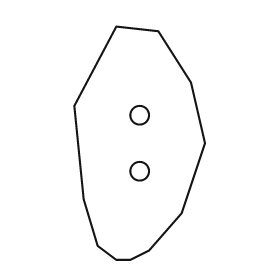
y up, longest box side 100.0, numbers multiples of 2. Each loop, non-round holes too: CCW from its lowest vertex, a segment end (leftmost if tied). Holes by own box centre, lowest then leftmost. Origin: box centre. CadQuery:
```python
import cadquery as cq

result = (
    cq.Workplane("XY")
    .moveTo(-10.0, -50.0)
    .lineTo(-4.0, -50.0)
    .lineTo(4.0, -46.0)
    .lineTo(18.0, -30.0)
    .lineTo(28.0, 0.0)
    .lineTo(22.0, 26.0)
    .lineTo(8.0, 48.0)
    .lineTo(-10.0, 50.0)
    .lineTo(-28.0, 16.0)
    .lineTo(-24.0, -24.0)
    .lineTo(-18.0, -44.0)
    .close()
    .moveTo(0.0, -12.0)
    .circle(4.0)
    .moveTo(0.0, 12.0)
    .circle(4.0)
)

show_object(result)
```